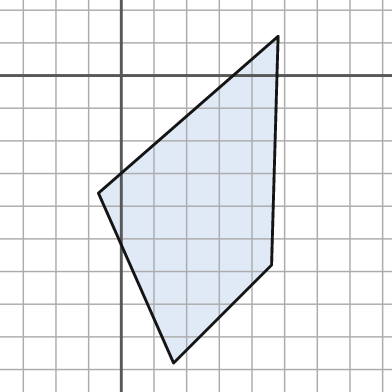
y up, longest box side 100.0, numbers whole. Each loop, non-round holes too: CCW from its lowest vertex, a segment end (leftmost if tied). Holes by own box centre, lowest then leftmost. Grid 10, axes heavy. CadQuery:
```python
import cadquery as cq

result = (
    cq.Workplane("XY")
    .moveTo(16.0, -88.0)
    .lineTo(46.0, -58.0)
    .lineTo(48.0, 12.0)
    .lineTo(-7.0, -36.0)
    .close()
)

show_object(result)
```